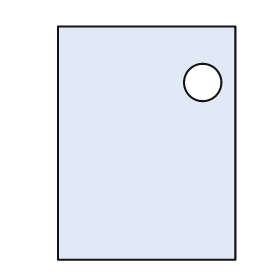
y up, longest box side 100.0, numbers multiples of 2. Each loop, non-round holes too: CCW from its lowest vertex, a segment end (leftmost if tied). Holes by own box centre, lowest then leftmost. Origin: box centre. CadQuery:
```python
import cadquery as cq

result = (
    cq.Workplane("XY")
    .moveTo(-38.0, -50.0)
    .lineTo(38.0, -50.0)
    .lineTo(38.0, 50.0)
    .lineTo(-38.0, 50.0)
    .close()
    .moveTo(24.0, 26.0)
    .circle(8.0)
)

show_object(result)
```